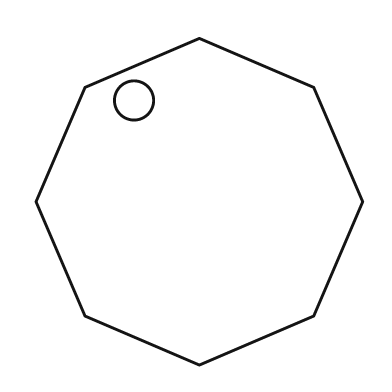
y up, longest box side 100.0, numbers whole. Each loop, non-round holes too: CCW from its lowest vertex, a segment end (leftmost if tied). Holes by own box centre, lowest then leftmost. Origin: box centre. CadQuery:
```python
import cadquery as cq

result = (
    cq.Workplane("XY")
    .moveTo(0.0, -50.0)
    .lineTo(35.0, -35.0)
    .lineTo(50.0, 0.0)
    .lineTo(35.0, 35.0)
    .lineTo(0.0, 50.0)
    .lineTo(-35.0, 35.0)
    .lineTo(-50.0, 0.0)
    .lineTo(-35.0, -35.0)
    .close()
    .moveTo(-20.0, 31.0)
    .circle(6.0)
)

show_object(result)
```